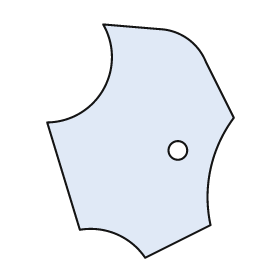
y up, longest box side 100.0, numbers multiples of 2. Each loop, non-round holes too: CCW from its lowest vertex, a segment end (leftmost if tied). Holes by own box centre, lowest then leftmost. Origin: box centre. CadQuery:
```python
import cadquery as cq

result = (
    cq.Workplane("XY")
    .moveTo(2.0, -50.0)
    .lineTo(30.0, -36.0)
    .threePointArc((30.0, -12.0), (40.0, 10.0))
    .lineTo(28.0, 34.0)
    .threePointArc((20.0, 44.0), (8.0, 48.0))
    .lineTo(-16.0, 50.0)
    .threePointArc((-16.0, 22.0), (-40.0, 8.0))
    .lineTo(-26.0, -38.0)
    .threePointArc((-10.0, -40.0), (2.0, -50.0))
    .close()
    .moveTo(16.0, -4.0)
    .circle(4.0)
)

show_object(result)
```